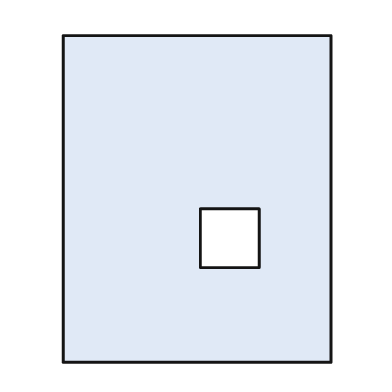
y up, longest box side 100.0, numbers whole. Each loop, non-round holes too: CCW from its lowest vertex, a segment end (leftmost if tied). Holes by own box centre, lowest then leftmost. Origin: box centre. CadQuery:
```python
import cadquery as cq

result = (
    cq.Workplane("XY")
    .moveTo(-41.0, -50.0)
    .lineTo(41.0, -50.0)
    .lineTo(41.0, 50.0)
    .lineTo(-41.0, 50.0)
    .close()
    .moveTo(1.0, -21.0)
    .lineTo(19.0, -21.0)
    .lineTo(19.0, -3.0)
    .lineTo(1.0, -3.0)
    .close()
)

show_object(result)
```